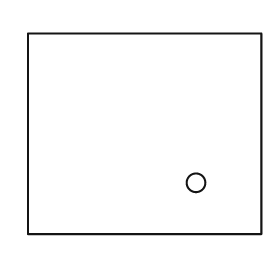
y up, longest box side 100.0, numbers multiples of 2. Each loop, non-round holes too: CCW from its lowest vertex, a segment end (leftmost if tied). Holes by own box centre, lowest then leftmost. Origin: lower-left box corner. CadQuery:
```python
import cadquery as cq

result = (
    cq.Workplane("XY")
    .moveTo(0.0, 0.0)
    .lineTo(100.0, 0.0)
    .lineTo(100.0, 86.0)
    .lineTo(0.0, 86.0)
    .close()
    .moveTo(72.0, 22.0)
    .circle(4.0)
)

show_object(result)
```